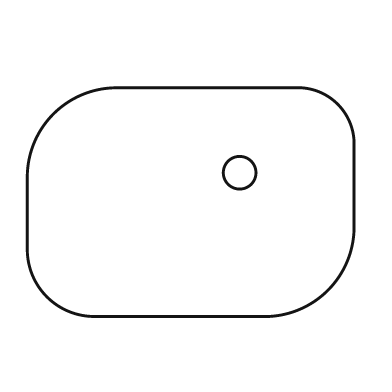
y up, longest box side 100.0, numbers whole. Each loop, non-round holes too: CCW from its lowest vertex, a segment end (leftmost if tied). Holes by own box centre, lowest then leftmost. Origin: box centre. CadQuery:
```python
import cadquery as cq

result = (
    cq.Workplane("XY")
    .moveTo(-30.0, -35.0)
    .lineTo(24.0, -35.0)
    .threePointArc((42.0, -27.0), (50.0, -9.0))
    .lineTo(50.0, 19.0)
    .threePointArc((45.0, 30.0), (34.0, 35.0))
    .lineTo(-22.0, 35.0)
    .threePointArc((-42.0, 27.0), (-50.0, 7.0))
    .lineTo(-50.0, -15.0)
    .threePointArc((-44.0, -29.0), (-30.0, -35.0))
    .close()
    .moveTo(15.0, 9.0)
    .circle(5.0)
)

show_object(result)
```